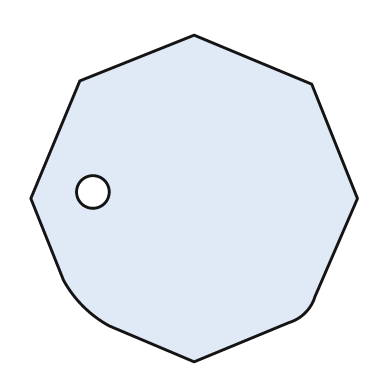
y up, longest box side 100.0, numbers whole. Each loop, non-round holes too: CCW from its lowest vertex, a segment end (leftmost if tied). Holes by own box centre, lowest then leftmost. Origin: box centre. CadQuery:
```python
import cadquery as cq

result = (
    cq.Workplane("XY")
    .moveTo(0.0, -50.0)
    .lineTo(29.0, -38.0)
    .threePointArc((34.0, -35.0), (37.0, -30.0))
    .lineTo(50.0, 0.0)
    .lineTo(36.0, 35.0)
    .lineTo(0.0, 50.0)
    .lineTo(-35.0, 36.0)
    .lineTo(-50.0, 0.0)
    .lineTo(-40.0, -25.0)
    .threePointArc((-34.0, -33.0), (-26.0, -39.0))
    .close()
    .moveTo(-31.0, 2.0)
    .circle(5.0)
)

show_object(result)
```